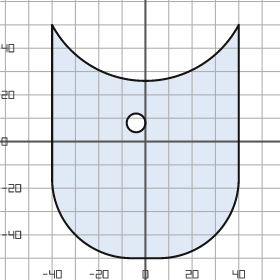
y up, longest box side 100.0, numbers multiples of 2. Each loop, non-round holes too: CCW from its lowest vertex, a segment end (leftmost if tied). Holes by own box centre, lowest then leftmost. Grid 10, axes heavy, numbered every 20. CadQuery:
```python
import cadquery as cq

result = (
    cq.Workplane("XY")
    .moveTo(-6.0, -50.0)
    .lineTo(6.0, -50.0)
    .threePointArc((30.0, -40.0), (40.0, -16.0))
    .lineTo(40.0, 50.0)
    .threePointArc((0.0, 26.0), (-40.0, 50.0))
    .lineTo(-40.0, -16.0)
    .threePointArc((-30.0, -40.0), (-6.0, -50.0))
    .close()
    .moveTo(-4.0, 8.0)
    .circle(4.0)
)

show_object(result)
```